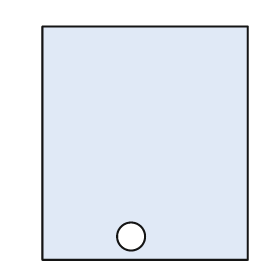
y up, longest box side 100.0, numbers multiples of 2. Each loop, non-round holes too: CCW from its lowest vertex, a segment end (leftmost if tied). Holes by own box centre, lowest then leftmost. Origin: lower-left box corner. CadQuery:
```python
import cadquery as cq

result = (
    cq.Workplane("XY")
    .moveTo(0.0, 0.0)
    .lineTo(88.0, 0.0)
    .lineTo(88.0, 100.0)
    .lineTo(0.0, 100.0)
    .close()
    .moveTo(38.0, 10.0)
    .circle(6.0)
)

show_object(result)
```